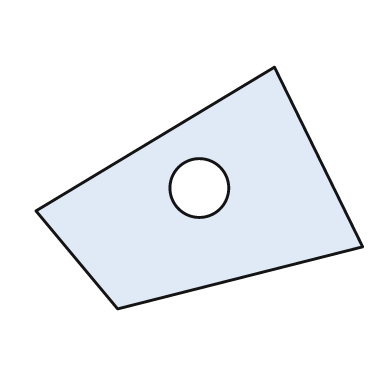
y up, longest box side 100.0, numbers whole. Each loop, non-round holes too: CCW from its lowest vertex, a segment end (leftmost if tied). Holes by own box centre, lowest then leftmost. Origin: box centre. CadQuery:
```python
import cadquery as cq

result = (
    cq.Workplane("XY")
    .moveTo(-25.0, -37.0)
    .lineTo(50.0, -18.0)
    .lineTo(23.0, 37.0)
    .lineTo(-50.0, -7.0)
    .close()
    .moveTo(0.0, 0.0)
    .circle(9.0)
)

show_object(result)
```